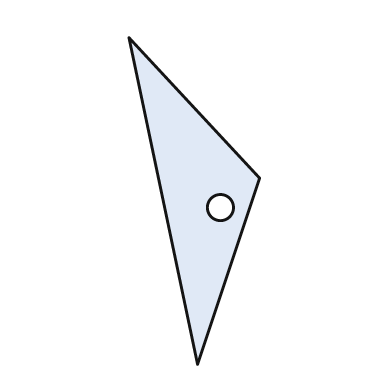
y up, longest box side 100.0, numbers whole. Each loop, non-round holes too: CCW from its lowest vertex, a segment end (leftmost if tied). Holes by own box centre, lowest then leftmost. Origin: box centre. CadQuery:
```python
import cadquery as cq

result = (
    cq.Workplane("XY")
    .moveTo(1.0, -50.0)
    .lineTo(20.0, 7.0)
    .lineTo(-20.0, 50.0)
    .close()
    .moveTo(8.0, -2.0)
    .circle(4.0)
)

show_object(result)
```